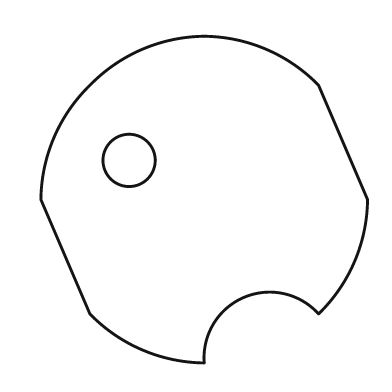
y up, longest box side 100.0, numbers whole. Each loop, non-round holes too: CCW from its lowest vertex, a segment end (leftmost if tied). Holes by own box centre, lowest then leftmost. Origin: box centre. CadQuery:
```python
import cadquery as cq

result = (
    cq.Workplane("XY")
    .moveTo(0.0, -50.0)
    .threePointArc((12.0, -30.0), (35.0, -35.0))
    .threePointArc((46.0, -19.0), (50.0, 0.0))
    .lineTo(35.0, 35.0)
    .threePointArc((19.0, 46.0), (0.0, 50.0))
    .threePointArc((-19.0, 46.0), (-35.0, 35.0))
    .threePointArc((-46.0, 19.0), (-50.0, 0.0))
    .lineTo(-35.0, -35.0)
    .threePointArc((-19.0, -46.0), (0.0, -50.0))
    .close()
    .moveTo(-23.0, 12.0)
    .circle(8.0)
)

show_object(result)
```